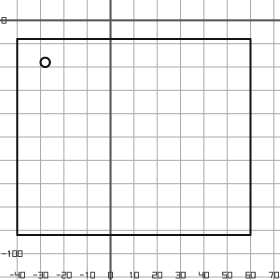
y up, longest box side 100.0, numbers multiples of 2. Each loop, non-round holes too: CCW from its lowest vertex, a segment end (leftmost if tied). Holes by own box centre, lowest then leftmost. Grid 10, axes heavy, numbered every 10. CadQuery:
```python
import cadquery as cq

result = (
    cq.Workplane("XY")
    .moveTo(-40.0, -92.0)
    .lineTo(60.0, -92.0)
    .lineTo(60.0, -8.0)
    .lineTo(-40.0, -8.0)
    .close()
    .moveTo(-28.0, -18.0)
    .circle(2.0)
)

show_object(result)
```